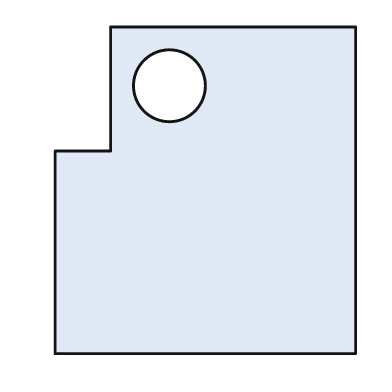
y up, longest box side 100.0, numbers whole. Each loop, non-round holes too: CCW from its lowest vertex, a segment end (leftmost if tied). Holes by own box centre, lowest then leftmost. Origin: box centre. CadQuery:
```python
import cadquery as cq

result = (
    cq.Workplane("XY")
    .moveTo(-46.0, -50.0)
    .lineTo(46.0, -50.0)
    .lineTo(46.0, 50.0)
    .lineTo(-29.0, 50.0)
    .lineTo(-29.0, 12.0)
    .lineTo(-46.0, 12.0)
    .close()
    .moveTo(-11.0, 32.0)
    .circle(11.0)
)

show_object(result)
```